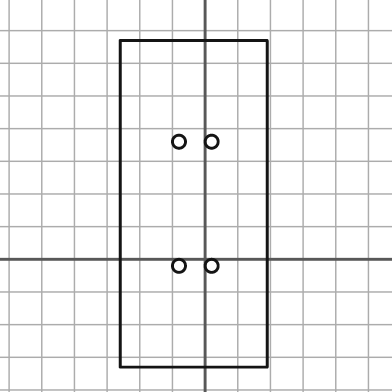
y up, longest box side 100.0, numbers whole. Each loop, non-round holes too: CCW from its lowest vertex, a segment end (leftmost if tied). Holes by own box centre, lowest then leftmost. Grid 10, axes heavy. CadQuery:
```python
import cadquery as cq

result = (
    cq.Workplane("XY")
    .moveTo(-26.0, -33.0)
    .lineTo(19.0, -33.0)
    .lineTo(19.0, 67.0)
    .lineTo(-26.0, 67.0)
    .close()
    .moveTo(-8.0, -2.0)
    .circle(2.0)
    .moveTo(2.0, -2.0)
    .circle(2.0)
    .moveTo(-8.0, 36.0)
    .circle(2.0)
    .moveTo(2.0, 36.0)
    .circle(2.0)
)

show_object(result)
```